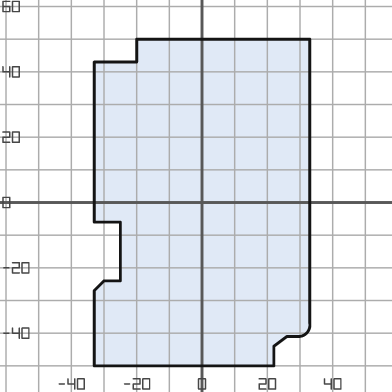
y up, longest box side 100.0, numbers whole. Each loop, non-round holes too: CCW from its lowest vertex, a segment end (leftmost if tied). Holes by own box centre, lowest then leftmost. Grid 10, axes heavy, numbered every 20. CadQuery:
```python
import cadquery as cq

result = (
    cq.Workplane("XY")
    .moveTo(-33.0, -50.0)
    .lineTo(22.0, -50.0)
    .lineTo(22.0, -44.0)
    .lineTo(26.0, -41.0)
    .lineTo(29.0, -41.0)
    .threePointArc((32.0, -40.0), (33.0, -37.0))
    .lineTo(33.0, 50.0)
    .lineTo(-20.0, 50.0)
    .lineTo(-20.0, 43.0)
    .lineTo(-33.0, 43.0)
    .lineTo(-33.0, -6.0)
    .lineTo(-25.0, -6.0)
    .lineTo(-25.0, -24.0)
    .lineTo(-30.0, -24.0)
    .lineTo(-33.0, -27.0)
    .close()
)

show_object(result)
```